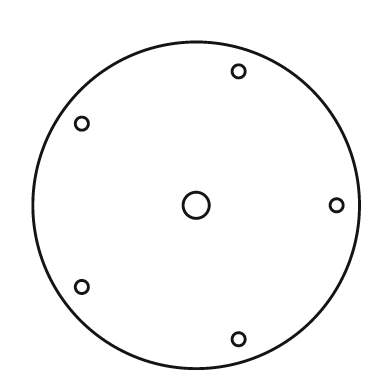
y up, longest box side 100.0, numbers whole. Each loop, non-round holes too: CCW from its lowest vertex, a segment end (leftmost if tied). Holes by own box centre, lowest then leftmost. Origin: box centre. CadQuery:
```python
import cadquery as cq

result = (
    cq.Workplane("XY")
    .moveTo(0.0, 0.0)
    .circle(50.0)
    .moveTo(13.0, -41.0)
    .circle(2.0)
    .moveTo(-35.0, -25.0)
    .circle(2.0)
    .moveTo(0.0, 0.0)
    .circle(4.0)
    .moveTo(43.0, 0.0)
    .circle(2.0)
    .moveTo(-35.0, 25.0)
    .circle(2.0)
    .moveTo(13.0, 41.0)
    .circle(2.0)
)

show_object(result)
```